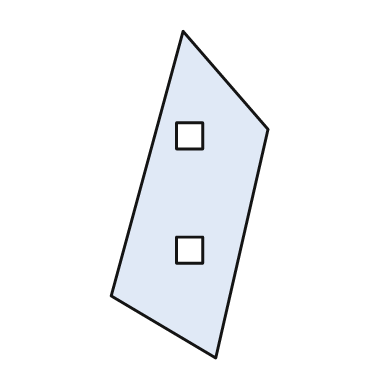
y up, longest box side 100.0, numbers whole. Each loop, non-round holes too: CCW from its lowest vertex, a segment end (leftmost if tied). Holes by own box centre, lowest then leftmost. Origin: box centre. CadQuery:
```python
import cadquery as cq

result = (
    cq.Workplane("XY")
    .moveTo(8.0, -50.0)
    .lineTo(24.0, 20.0)
    .lineTo(-2.0, 50.0)
    .lineTo(-24.0, -31.0)
    .close()
    .moveTo(-4.0, -21.0)
    .lineTo(4.0, -21.0)
    .lineTo(4.0, -13.0)
    .lineTo(-4.0, -13.0)
    .close()
    .moveTo(-4.0, 14.0)
    .lineTo(4.0, 14.0)
    .lineTo(4.0, 22.0)
    .lineTo(-4.0, 22.0)
    .close()
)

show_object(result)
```